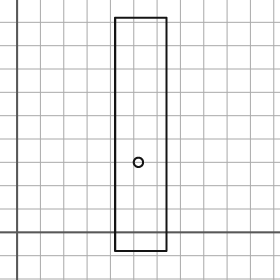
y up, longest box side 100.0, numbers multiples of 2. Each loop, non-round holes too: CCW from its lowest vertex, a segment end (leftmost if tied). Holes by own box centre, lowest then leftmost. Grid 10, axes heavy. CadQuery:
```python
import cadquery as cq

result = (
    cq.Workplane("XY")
    .moveTo(42.0, -8.0)
    .lineTo(64.0, -8.0)
    .lineTo(64.0, 92.0)
    .lineTo(42.0, 92.0)
    .close()
    .moveTo(52.0, 30.0)
    .circle(2.0)
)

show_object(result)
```